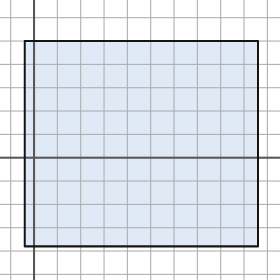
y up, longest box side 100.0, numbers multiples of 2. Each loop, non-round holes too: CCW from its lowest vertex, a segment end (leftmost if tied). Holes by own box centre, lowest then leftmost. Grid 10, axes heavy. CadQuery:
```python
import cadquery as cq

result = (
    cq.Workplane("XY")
    .moveTo(-4.0, -38.0)
    .lineTo(96.0, -38.0)
    .lineTo(96.0, 50.0)
    .lineTo(-4.0, 50.0)
    .close()
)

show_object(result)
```